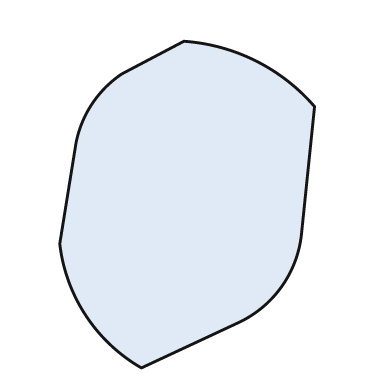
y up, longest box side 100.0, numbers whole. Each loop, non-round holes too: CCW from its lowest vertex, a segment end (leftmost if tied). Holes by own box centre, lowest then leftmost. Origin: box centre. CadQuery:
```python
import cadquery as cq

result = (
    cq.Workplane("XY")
    .moveTo(-14.0, -50.0)
    .lineTo(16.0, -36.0)
    .threePointArc((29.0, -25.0), (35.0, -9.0))
    .lineTo(39.0, 30.0)
    .threePointArc((21.0, 44.0), (-1.0, 50.0))
    .lineTo(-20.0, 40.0)
    .threePointArc((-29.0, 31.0), (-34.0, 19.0))
    .lineTo(-39.0, -12.0)
    .threePointArc((-31.0, -34.0), (-14.0, -50.0))
    .close()
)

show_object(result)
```